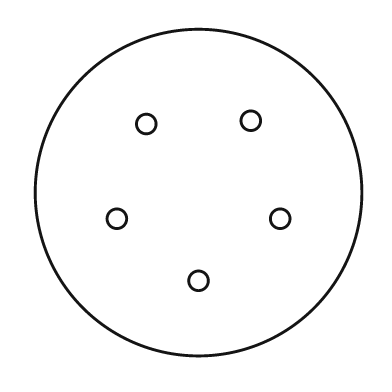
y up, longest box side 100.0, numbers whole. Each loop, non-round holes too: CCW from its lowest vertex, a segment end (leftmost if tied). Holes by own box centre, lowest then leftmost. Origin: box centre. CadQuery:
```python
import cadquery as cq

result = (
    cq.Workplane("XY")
    .moveTo(0.0, 0.0)
    .circle(50.0)
    .moveTo(0.0, -27.0)
    .circle(3.0)
    .moveTo(-25.0, -8.0)
    .circle(3.0)
    .moveTo(25.0, -8.0)
    .circle(3.0)
    .moveTo(-16.0, 21.0)
    .circle(3.0)
    .moveTo(16.0, 22.0)
    .circle(3.0)
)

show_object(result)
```